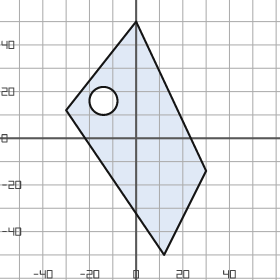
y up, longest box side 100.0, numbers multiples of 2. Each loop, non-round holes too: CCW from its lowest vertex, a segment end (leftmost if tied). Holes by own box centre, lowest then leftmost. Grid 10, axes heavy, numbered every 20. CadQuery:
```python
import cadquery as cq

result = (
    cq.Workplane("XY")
    .moveTo(12.0, -50.0)
    .lineTo(30.0, -14.0)
    .lineTo(0.0, 50.0)
    .lineTo(-30.0, 12.0)
    .close()
    .moveTo(-14.0, 16.0)
    .circle(6.0)
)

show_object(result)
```